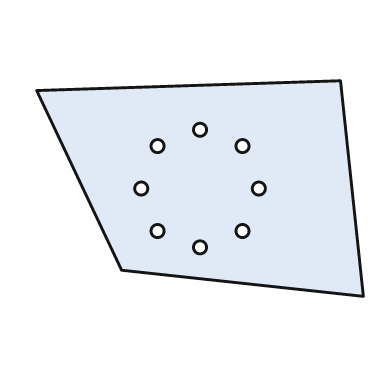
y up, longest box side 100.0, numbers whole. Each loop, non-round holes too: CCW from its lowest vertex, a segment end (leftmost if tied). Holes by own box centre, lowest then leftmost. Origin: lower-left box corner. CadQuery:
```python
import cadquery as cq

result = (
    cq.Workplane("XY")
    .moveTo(100.0, 0.0)
    .lineTo(93.0, 66.0)
    .lineTo(0.0, 63.0)
    .lineTo(26.0, 8.0)
    .close()
    .moveTo(50.0, 15.0)
    .circle(2.0)
    .moveTo(37.0, 20.0)
    .circle(2.0)
    .moveTo(63.0, 20.0)
    .circle(2.0)
    .moveTo(32.0, 33.0)
    .circle(2.0)
    .moveTo(68.0, 33.0)
    .circle(2.0)
    .moveTo(37.0, 46.0)
    .circle(2.0)
    .moveTo(63.0, 46.0)
    .circle(2.0)
    .moveTo(50.0, 51.0)
    .circle(2.0)
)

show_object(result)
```